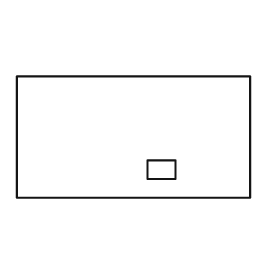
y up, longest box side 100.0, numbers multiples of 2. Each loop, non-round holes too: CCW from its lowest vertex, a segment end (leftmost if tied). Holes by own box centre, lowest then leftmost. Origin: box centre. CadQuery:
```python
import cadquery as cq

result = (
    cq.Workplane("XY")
    .moveTo(-50.0, -26.0)
    .lineTo(50.0, -26.0)
    .lineTo(50.0, 26.0)
    .lineTo(-50.0, 26.0)
    .close()
    .moveTo(6.0, -18.0)
    .lineTo(18.0, -18.0)
    .lineTo(18.0, -10.0)
    .lineTo(6.0, -10.0)
    .close()
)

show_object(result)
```